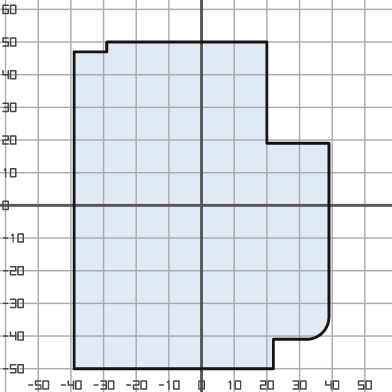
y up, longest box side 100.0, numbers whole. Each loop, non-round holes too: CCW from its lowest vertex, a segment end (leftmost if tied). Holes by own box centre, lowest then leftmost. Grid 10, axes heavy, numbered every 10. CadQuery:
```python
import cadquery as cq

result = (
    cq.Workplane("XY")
    .moveTo(-39.0, -50.0)
    .lineTo(22.0, -50.0)
    .lineTo(22.0, -41.0)
    .lineTo(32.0, -41.0)
    .threePointArc((37.0, -39.0), (39.0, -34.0))
    .lineTo(39.0, 19.0)
    .lineTo(20.0, 19.0)
    .lineTo(20.0, 50.0)
    .lineTo(-29.0, 50.0)
    .lineTo(-29.0, 47.0)
    .lineTo(-39.0, 47.0)
    .close()
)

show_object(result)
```